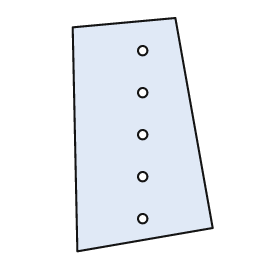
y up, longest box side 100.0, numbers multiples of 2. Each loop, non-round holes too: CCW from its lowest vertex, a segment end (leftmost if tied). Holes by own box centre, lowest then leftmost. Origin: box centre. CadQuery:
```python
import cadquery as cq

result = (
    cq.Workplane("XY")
    .moveTo(-28.0, -50.0)
    .lineTo(30.0, -40.0)
    .lineTo(14.0, 50.0)
    .lineTo(-30.0, 46.0)
    .close()
    .moveTo(0.0, -36.0)
    .circle(2.0)
    .moveTo(0.0, -18.0)
    .circle(2.0)
    .moveTo(0.0, 0.0)
    .circle(2.0)
    .moveTo(0.0, 18.0)
    .circle(2.0)
    .moveTo(0.0, 36.0)
    .circle(2.0)
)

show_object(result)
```